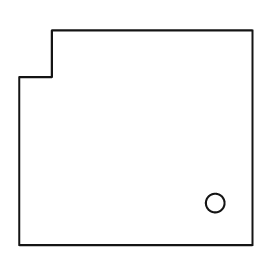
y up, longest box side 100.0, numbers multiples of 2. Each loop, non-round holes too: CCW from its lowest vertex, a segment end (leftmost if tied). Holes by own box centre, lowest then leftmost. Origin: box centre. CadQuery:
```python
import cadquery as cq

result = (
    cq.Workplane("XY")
    .moveTo(-50.0, -46.0)
    .lineTo(50.0, -46.0)
    .lineTo(50.0, 46.0)
    .lineTo(-36.0, 46.0)
    .lineTo(-36.0, 26.0)
    .lineTo(-50.0, 26.0)
    .close()
    .moveTo(34.0, -28.0)
    .circle(4.0)
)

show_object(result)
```